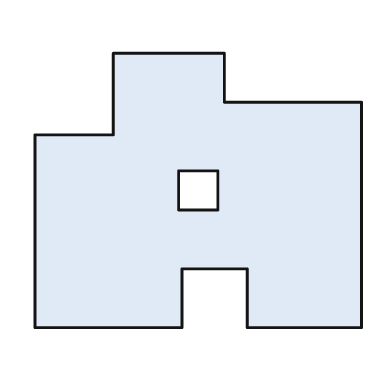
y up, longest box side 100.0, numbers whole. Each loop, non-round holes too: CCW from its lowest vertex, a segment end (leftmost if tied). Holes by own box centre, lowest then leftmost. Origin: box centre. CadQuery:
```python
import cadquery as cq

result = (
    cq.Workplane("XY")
    .moveTo(-50.0, -42.0)
    .lineTo(-5.0, -42.0)
    .lineTo(-5.0, -24.0)
    .lineTo(15.0, -24.0)
    .lineTo(15.0, -42.0)
    .lineTo(50.0, -42.0)
    .lineTo(50.0, 27.0)
    .lineTo(8.0, 27.0)
    .lineTo(8.0, 42.0)
    .lineTo(-26.0, 42.0)
    .lineTo(-26.0, 17.0)
    .lineTo(-50.0, 17.0)
    .close()
    .moveTo(-6.0, -6.0)
    .lineTo(6.0, -6.0)
    .lineTo(6.0, 6.0)
    .lineTo(-6.0, 6.0)
    .close()
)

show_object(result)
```